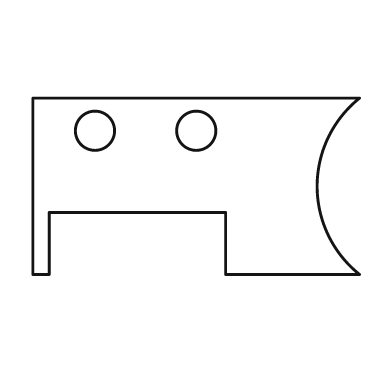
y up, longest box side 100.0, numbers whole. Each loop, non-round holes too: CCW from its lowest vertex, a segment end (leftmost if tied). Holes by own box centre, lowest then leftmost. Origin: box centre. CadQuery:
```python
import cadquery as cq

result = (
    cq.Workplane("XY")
    .moveTo(-50.0, -27.0)
    .lineTo(-45.0, -27.0)
    .lineTo(-45.0, -8.0)
    .lineTo(9.0, -8.0)
    .lineTo(9.0, -27.0)
    .lineTo(50.0, -27.0)
    .threePointArc((37.0, 0.0), (50.0, 27.0))
    .lineTo(-50.0, 27.0)
    .close()
    .moveTo(-31.0, 17.0)
    .circle(6.0)
    .moveTo(0.0, 17.0)
    .circle(6.0)
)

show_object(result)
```